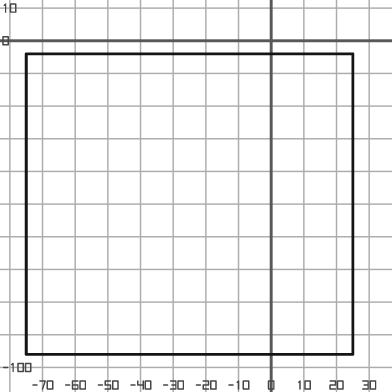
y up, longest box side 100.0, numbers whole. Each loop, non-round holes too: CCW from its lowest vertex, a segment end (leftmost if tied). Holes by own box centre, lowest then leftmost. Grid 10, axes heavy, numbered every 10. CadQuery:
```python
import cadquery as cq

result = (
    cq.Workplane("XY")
    .moveTo(-75.0, -96.0)
    .lineTo(25.0, -96.0)
    .lineTo(25.0, -4.0)
    .lineTo(-75.0, -4.0)
    .close()
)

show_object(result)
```